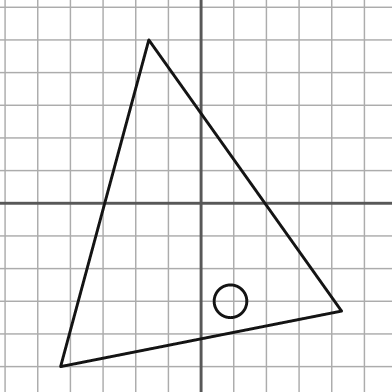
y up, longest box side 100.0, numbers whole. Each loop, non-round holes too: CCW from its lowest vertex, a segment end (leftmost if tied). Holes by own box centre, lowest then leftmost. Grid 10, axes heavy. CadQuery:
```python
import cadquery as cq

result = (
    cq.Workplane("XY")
    .moveTo(-43.0, -50.0)
    .lineTo(43.0, -33.0)
    .lineTo(-16.0, 50.0)
    .close()
    .moveTo(9.0, -30.0)
    .circle(5.0)
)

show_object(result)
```